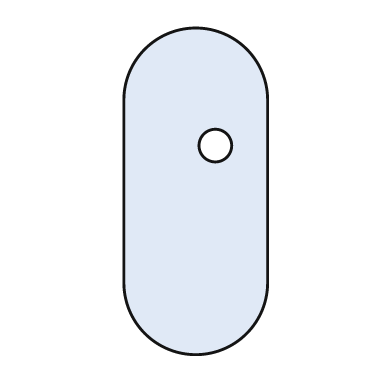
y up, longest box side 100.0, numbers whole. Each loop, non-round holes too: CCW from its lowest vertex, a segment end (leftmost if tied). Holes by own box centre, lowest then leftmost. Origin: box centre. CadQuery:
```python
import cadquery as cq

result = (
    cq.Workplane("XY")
    .moveTo(-22.0, -28.0)
    .threePointArc((0.0, -50.0), (22.0, -28.0))
    .lineTo(22.0, 28.0)
    .threePointArc((0.0, 50.0), (-22.0, 28.0))
    .close()
    .moveTo(6.0, 14.0)
    .circle(5.0)
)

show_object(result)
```